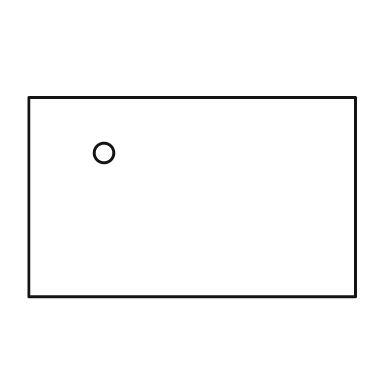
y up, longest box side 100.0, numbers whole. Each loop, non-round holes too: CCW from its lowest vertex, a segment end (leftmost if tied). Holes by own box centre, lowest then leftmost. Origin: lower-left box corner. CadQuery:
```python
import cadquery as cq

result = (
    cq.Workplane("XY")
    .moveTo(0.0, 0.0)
    .lineTo(100.0, 0.0)
    .lineTo(100.0, 61.0)
    .lineTo(0.0, 61.0)
    .close()
    .moveTo(23.0, 44.0)
    .circle(3.0)
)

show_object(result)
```